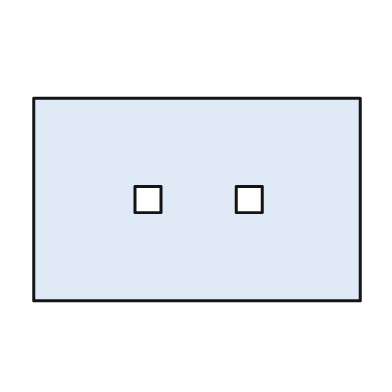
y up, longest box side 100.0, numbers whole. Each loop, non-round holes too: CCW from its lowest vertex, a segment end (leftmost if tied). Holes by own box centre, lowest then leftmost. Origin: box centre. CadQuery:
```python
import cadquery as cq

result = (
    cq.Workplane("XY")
    .moveTo(-50.0, -31.0)
    .lineTo(50.0, -31.0)
    .lineTo(50.0, 31.0)
    .lineTo(-50.0, 31.0)
    .close()
    .moveTo(-19.0, -4.0)
    .lineTo(-11.0, -4.0)
    .lineTo(-11.0, 4.0)
    .lineTo(-19.0, 4.0)
    .close()
    .moveTo(12.0, -4.0)
    .lineTo(20.0, -4.0)
    .lineTo(20.0, 4.0)
    .lineTo(12.0, 4.0)
    .close()
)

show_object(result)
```